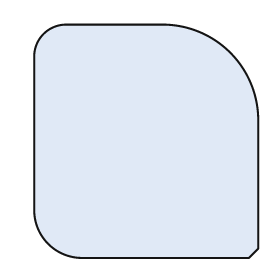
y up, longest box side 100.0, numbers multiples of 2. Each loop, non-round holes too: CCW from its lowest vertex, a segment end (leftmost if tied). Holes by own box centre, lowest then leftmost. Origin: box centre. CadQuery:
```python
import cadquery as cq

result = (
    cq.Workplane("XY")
    .moveTo(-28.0, -50.0)
    .lineTo(44.0, -50.0)
    .lineTo(48.0, -46.0)
    .lineTo(48.0, 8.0)
    .threePointArc((36.0, 38.0), (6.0, 50.0))
    .lineTo(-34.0, 50.0)
    .threePointArc((-44.0, 46.0), (-48.0, 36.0))
    .lineTo(-48.0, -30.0)
    .threePointArc((-42.0, -44.0), (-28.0, -50.0))
    .close()
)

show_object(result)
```